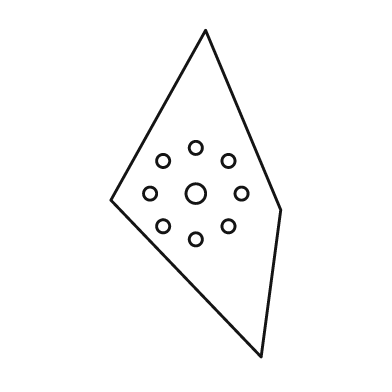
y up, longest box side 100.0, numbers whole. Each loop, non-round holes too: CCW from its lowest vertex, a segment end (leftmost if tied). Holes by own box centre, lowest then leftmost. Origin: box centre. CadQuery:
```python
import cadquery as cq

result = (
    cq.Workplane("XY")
    .moveTo(20.0, -50.0)
    .lineTo(26.0, -5.0)
    .lineTo(3.0, 50.0)
    .lineTo(-26.0, -2.0)
    .close()
    .moveTo(0.0, -14.0)
    .circle(2.0)
    .moveTo(-10.0, -10.0)
    .circle(2.0)
    .moveTo(10.0, -10.0)
    .circle(2.0)
    .moveTo(-14.0, 0.0)
    .circle(2.0)
    .moveTo(0.0, 0.0)
    .circle(3.0)
    .moveTo(14.0, 0.0)
    .circle(2.0)
    .moveTo(-10.0, 10.0)
    .circle(2.0)
    .moveTo(10.0, 10.0)
    .circle(2.0)
    .moveTo(0.0, 14.0)
    .circle(2.0)
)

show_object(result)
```